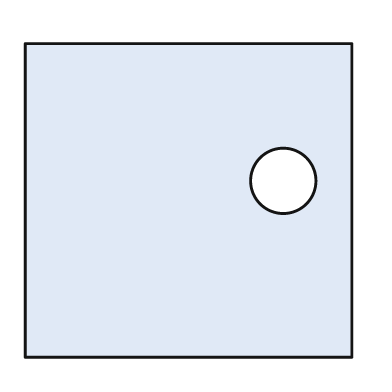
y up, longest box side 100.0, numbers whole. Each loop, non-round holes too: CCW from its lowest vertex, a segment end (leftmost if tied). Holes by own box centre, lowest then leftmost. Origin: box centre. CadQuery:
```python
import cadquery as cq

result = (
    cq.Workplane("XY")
    .moveTo(-50.0, -48.0)
    .lineTo(50.0, -48.0)
    .lineTo(50.0, 48.0)
    .lineTo(-50.0, 48.0)
    .close()
    .moveTo(29.0, 6.0)
    .circle(10.0)
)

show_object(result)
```